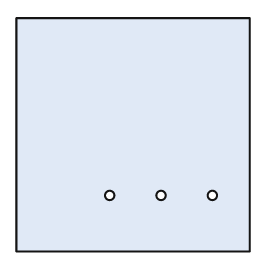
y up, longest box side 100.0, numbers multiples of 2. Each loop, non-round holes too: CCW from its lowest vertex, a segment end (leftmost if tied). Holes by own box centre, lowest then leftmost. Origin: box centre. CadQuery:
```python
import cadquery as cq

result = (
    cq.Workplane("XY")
    .moveTo(-50.0, -50.0)
    .lineTo(50.0, -50.0)
    .lineTo(50.0, 50.0)
    .lineTo(-50.0, 50.0)
    .close()
    .moveTo(-10.0, -26.0)
    .circle(2.0)
    .moveTo(12.0, -26.0)
    .circle(2.0)
    .moveTo(34.0, -26.0)
    .circle(2.0)
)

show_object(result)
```